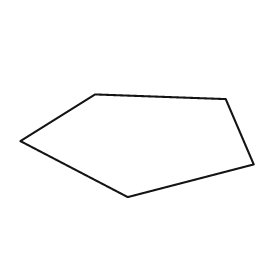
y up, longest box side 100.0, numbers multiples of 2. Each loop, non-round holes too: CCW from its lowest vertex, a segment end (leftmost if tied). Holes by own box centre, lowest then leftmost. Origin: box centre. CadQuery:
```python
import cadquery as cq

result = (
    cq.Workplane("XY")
    .moveTo(-4.0, -22.0)
    .lineTo(50.0, -8.0)
    .lineTo(38.0, 20.0)
    .lineTo(-18.0, 22.0)
    .lineTo(-50.0, 2.0)
    .close()
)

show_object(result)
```